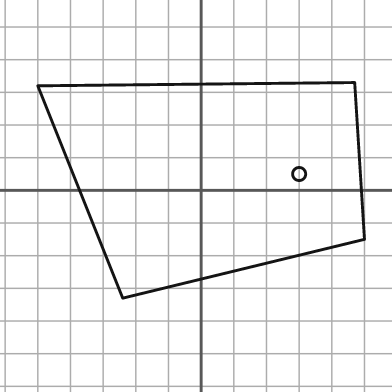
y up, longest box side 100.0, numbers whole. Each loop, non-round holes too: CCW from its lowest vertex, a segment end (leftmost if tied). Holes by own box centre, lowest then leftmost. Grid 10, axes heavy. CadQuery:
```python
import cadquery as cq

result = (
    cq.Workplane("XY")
    .moveTo(-24.0, -33.0)
    .lineTo(50.0, -15.0)
    .lineTo(47.0, 33.0)
    .lineTo(-50.0, 32.0)
    .close()
    .moveTo(30.0, 5.0)
    .circle(2.0)
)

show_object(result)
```